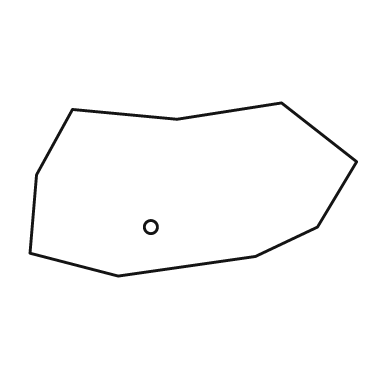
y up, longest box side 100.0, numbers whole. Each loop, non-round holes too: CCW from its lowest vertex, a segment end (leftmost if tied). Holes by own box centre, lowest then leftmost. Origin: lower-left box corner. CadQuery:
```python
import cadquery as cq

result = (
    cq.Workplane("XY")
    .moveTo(27.0, 0.0)
    .lineTo(69.0, 6.0)
    .lineTo(88.0, 15.0)
    .lineTo(100.0, 35.0)
    .lineTo(77.0, 53.0)
    .lineTo(45.0, 48.0)
    .lineTo(13.0, 51.0)
    .lineTo(2.0, 31.0)
    .lineTo(0.0, 7.0)
    .close()
    .moveTo(37.0, 15.0)
    .circle(2.0)
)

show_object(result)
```